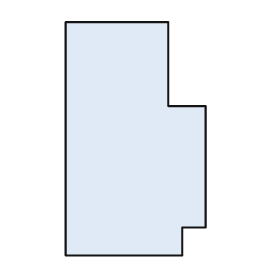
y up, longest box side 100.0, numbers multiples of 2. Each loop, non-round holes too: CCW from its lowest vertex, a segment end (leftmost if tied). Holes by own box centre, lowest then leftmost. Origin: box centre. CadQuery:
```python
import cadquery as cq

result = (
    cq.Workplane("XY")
    .moveTo(-30.0, -50.0)
    .lineTo(20.0, -50.0)
    .lineTo(20.0, -38.0)
    .lineTo(30.0, -38.0)
    .lineTo(30.0, 14.0)
    .lineTo(14.0, 14.0)
    .lineTo(14.0, 50.0)
    .lineTo(-30.0, 50.0)
    .close()
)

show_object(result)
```